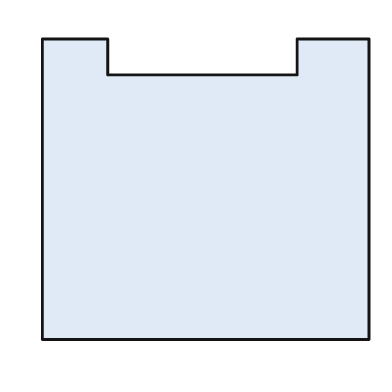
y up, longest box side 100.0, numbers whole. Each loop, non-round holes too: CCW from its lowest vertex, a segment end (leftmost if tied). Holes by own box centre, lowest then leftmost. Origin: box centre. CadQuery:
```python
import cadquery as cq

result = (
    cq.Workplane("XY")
    .moveTo(-50.0, -46.0)
    .lineTo(50.0, -46.0)
    .lineTo(50.0, 46.0)
    .lineTo(28.0, 46.0)
    .lineTo(28.0, 35.0)
    .lineTo(-30.0, 35.0)
    .lineTo(-30.0, 46.0)
    .lineTo(-50.0, 46.0)
    .close()
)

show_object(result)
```